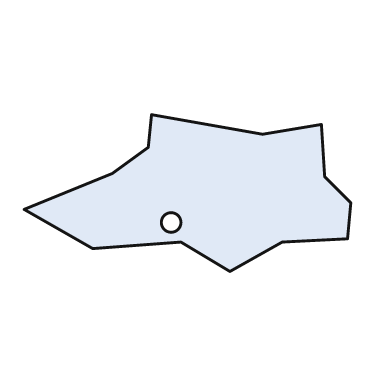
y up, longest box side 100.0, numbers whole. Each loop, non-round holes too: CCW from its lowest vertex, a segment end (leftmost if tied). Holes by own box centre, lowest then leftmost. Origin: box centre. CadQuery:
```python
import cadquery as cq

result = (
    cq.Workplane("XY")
    .moveTo(13.0, -24.0)
    .lineTo(29.0, -15.0)
    .lineTo(49.0, -14.0)
    .lineTo(50.0, -3.0)
    .lineTo(42.0, 5.0)
    .lineTo(41.0, 21.0)
    .lineTo(23.0, 18.0)
    .lineTo(-11.0, 24.0)
    .lineTo(-12.0, 14.0)
    .lineTo(-23.0, 6.0)
    .lineTo(-50.0, -5.0)
    .lineTo(-29.0, -17.0)
    .lineTo(-2.0, -15.0)
    .close()
    .moveTo(-5.0, -9.0)
    .circle(3.0)
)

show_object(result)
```